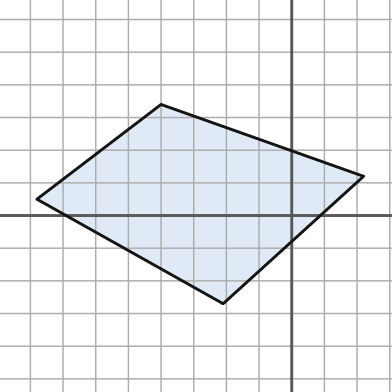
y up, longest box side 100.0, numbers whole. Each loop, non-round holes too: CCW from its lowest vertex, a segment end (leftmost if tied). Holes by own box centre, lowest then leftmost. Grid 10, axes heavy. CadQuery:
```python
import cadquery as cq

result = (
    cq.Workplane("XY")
    .moveTo(-21.0, -27.0)
    .lineTo(22.0, 12.0)
    .lineTo(-40.0, 34.0)
    .lineTo(-78.0, 5.0)
    .close()
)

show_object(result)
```